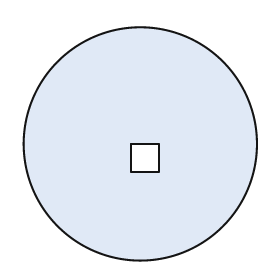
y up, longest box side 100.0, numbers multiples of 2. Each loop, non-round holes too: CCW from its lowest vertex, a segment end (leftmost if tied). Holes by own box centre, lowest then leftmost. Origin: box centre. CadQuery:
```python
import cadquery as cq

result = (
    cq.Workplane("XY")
    .moveTo(0.0, 0.0)
    .circle(50.0)
    .moveTo(-4.0, -12.0)
    .lineTo(8.0, -12.0)
    .lineTo(8.0, 0.0)
    .lineTo(-4.0, 0.0)
    .close()
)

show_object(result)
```